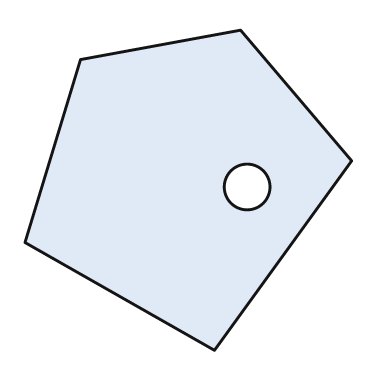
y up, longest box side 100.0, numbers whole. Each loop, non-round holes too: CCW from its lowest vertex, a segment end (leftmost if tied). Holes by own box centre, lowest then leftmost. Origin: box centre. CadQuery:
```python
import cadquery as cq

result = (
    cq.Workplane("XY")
    .moveTo(8.0, -49.0)
    .lineTo(50.0, 9.0)
    .lineTo(16.0, 49.0)
    .lineTo(-33.0, 40.0)
    .lineTo(-50.0, -16.0)
    .close()
    .moveTo(18.0, 1.0)
    .circle(7.0)
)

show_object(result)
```